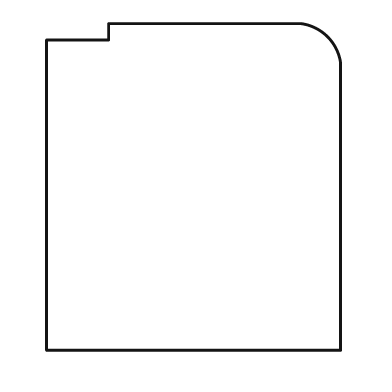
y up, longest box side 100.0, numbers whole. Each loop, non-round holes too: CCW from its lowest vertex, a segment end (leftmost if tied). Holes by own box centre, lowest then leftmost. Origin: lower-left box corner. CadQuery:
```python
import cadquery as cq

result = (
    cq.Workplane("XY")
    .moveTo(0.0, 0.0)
    .lineTo(90.0, 0.0)
    .lineTo(90.0, 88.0)
    .threePointArc((86.0, 96.0), (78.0, 100.0))
    .lineTo(19.0, 100.0)
    .lineTo(19.0, 95.0)
    .lineTo(0.0, 95.0)
    .close()
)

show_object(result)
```